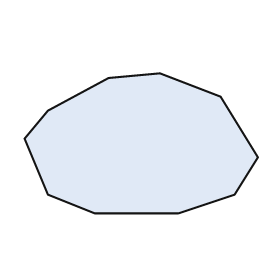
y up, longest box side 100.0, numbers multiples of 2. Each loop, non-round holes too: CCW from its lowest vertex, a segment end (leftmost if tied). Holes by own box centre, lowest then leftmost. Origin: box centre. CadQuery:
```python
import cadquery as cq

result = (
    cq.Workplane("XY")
    .moveTo(-20.0, -30.0)
    .lineTo(16.0, -30.0)
    .lineTo(40.0, -22.0)
    .lineTo(50.0, -6.0)
    .lineTo(34.0, 20.0)
    .lineTo(8.0, 30.0)
    .lineTo(-14.0, 28.0)
    .lineTo(-40.0, 14.0)
    .lineTo(-50.0, 2.0)
    .lineTo(-40.0, -22.0)
    .close()
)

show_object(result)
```